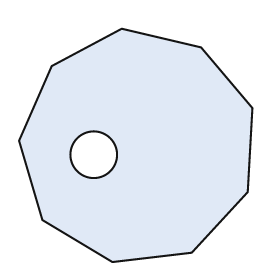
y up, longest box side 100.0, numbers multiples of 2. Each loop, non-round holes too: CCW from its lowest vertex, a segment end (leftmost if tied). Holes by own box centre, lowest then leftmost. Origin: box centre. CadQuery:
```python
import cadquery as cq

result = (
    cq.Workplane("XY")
    .moveTo(-10.0, -50.0)
    .lineTo(24.0, -46.0)
    .lineTo(48.0, -20.0)
    .lineTo(50.0, 16.0)
    .lineTo(28.0, 42.0)
    .lineTo(-6.0, 50.0)
    .lineTo(-36.0, 34.0)
    .lineTo(-50.0, 2.0)
    .lineTo(-40.0, -32.0)
    .close()
    .moveTo(-18.0, -4.0)
    .circle(10.0)
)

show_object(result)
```